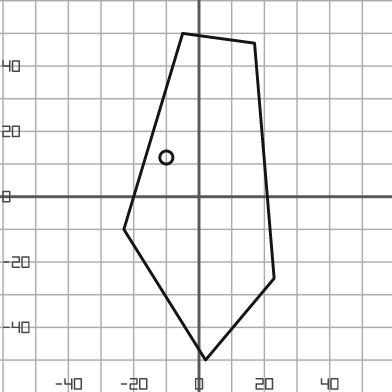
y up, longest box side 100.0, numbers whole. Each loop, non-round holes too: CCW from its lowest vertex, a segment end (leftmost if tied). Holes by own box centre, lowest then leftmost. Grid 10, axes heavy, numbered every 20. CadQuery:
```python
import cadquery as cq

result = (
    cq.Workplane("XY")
    .moveTo(2.0, -50.0)
    .lineTo(23.0, -25.0)
    .lineTo(17.0, 47.0)
    .lineTo(-5.0, 50.0)
    .lineTo(-23.0, -10.0)
    .close()
    .moveTo(-10.0, 12.0)
    .circle(2.0)
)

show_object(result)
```